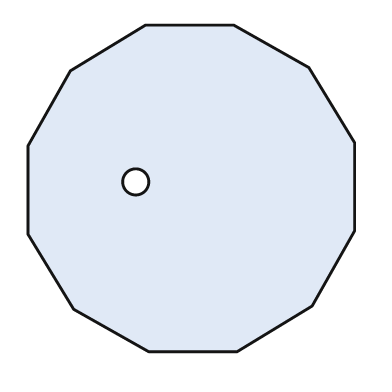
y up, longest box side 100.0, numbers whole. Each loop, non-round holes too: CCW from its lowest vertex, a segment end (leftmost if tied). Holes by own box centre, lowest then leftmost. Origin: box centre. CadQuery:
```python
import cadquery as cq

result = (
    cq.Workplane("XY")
    .moveTo(-13.0, -50.0)
    .lineTo(14.0, -50.0)
    .lineTo(37.0, -36.0)
    .lineTo(50.0, -13.0)
    .lineTo(50.0, 14.0)
    .lineTo(36.0, 37.0)
    .lineTo(13.0, 50.0)
    .lineTo(-14.0, 50.0)
    .lineTo(-37.0, 36.0)
    .lineTo(-50.0, 13.0)
    .lineTo(-50.0, -14.0)
    .lineTo(-36.0, -37.0)
    .close()
    .moveTo(-17.0, 2.0)
    .circle(4.0)
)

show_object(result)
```